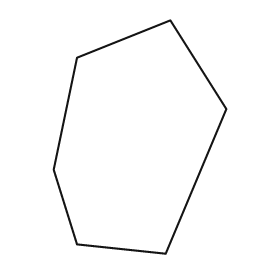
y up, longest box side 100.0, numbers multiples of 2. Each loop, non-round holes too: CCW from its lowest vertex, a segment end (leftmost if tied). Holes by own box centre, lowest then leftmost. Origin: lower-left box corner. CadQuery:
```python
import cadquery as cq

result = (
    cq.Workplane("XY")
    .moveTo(48.0, 0.0)
    .lineTo(74.0, 62.0)
    .lineTo(50.0, 100.0)
    .lineTo(10.0, 84.0)
    .lineTo(0.0, 36.0)
    .lineTo(10.0, 4.0)
    .close()
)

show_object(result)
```